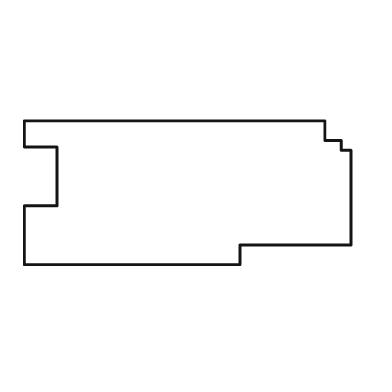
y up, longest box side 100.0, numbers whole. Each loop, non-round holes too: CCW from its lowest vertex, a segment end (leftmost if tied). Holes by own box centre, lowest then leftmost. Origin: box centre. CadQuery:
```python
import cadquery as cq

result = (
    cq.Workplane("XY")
    .moveTo(-50.0, -22.0)
    .lineTo(16.0, -22.0)
    .lineTo(16.0, -16.0)
    .lineTo(50.0, -16.0)
    .lineTo(50.0, 13.0)
    .lineTo(47.0, 13.0)
    .lineTo(47.0, 16.0)
    .lineTo(42.0, 16.0)
    .lineTo(42.0, 22.0)
    .lineTo(-50.0, 22.0)
    .lineTo(-50.0, 14.0)
    .lineTo(-40.0, 14.0)
    .lineTo(-40.0, -4.0)
    .lineTo(-50.0, -4.0)
    .close()
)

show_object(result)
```